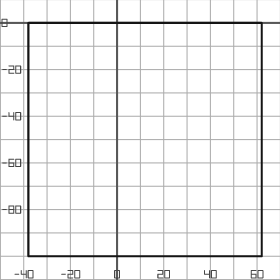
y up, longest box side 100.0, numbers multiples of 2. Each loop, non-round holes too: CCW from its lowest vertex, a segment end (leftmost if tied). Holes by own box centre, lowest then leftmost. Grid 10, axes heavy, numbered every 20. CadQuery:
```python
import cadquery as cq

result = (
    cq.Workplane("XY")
    .moveTo(-38.0, -100.0)
    .lineTo(62.0, -100.0)
    .lineTo(62.0, 0.0)
    .lineTo(-38.0, 0.0)
    .close()
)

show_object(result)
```